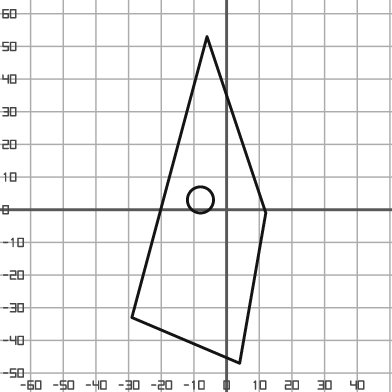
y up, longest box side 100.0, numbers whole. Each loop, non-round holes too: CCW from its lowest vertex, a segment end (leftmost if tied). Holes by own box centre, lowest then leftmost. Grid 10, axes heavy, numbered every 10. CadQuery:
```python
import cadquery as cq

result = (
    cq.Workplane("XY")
    .moveTo(4.0, -47.0)
    .lineTo(12.0, -1.0)
    .lineTo(-6.0, 53.0)
    .lineTo(-29.0, -33.0)
    .close()
    .moveTo(-8.0, 3.0)
    .circle(4.0)
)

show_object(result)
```